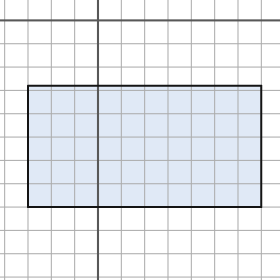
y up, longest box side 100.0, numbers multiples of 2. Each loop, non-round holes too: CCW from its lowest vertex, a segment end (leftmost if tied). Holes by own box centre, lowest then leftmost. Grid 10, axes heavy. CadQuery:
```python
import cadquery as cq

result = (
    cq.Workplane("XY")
    .moveTo(-30.0, -80.0)
    .lineTo(70.0, -80.0)
    .lineTo(70.0, -28.0)
    .lineTo(-30.0, -28.0)
    .close()
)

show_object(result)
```